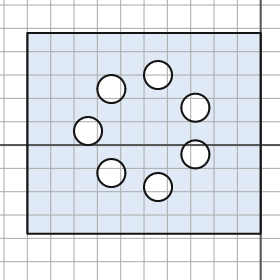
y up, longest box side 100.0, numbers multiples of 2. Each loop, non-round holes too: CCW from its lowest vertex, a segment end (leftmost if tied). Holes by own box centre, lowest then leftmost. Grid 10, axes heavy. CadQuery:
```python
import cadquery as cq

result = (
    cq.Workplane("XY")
    .moveTo(-100.0, -38.0)
    .lineTo(0.0, -38.0)
    .lineTo(0.0, 48.0)
    .lineTo(-100.0, 48.0)
    .close()
    .moveTo(-44.0, -18.0)
    .circle(6.0)
    .moveTo(-64.0, -12.0)
    .circle(6.0)
    .moveTo(-28.0, -4.0)
    .circle(6.0)
    .moveTo(-74.0, 6.0)
    .circle(6.0)
    .moveTo(-28.0, 16.0)
    .circle(6.0)
    .moveTo(-64.0, 24.0)
    .circle(6.0)
    .moveTo(-44.0, 30.0)
    .circle(6.0)
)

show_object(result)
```